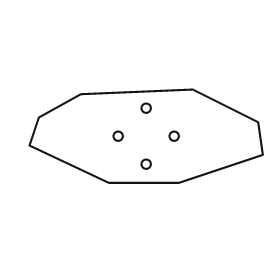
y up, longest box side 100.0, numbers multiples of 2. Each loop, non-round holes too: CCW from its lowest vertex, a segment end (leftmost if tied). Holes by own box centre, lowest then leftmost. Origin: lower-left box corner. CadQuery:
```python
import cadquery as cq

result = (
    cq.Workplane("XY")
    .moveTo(34.0, 0.0)
    .lineTo(64.0, 0.0)
    .lineTo(100.0, 12.0)
    .lineTo(98.0, 26.0)
    .lineTo(70.0, 40.0)
    .lineTo(22.0, 38.0)
    .lineTo(4.0, 28.0)
    .lineTo(0.0, 16.0)
    .close()
    .moveTo(50.0, 8.0)
    .circle(2.0)
    .moveTo(38.0, 20.0)
    .circle(2.0)
    .moveTo(62.0, 20.0)
    .circle(2.0)
    .moveTo(50.0, 32.0)
    .circle(2.0)
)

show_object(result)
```